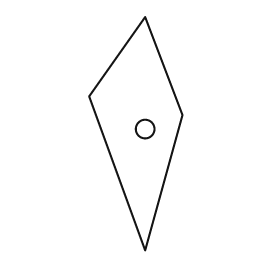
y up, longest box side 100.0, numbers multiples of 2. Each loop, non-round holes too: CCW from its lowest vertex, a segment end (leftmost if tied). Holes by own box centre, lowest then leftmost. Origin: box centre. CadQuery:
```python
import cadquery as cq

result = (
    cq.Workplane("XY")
    .moveTo(4.0, -50.0)
    .lineTo(20.0, 8.0)
    .lineTo(4.0, 50.0)
    .lineTo(-20.0, 16.0)
    .close()
    .moveTo(4.0, 2.0)
    .circle(4.0)
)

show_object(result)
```